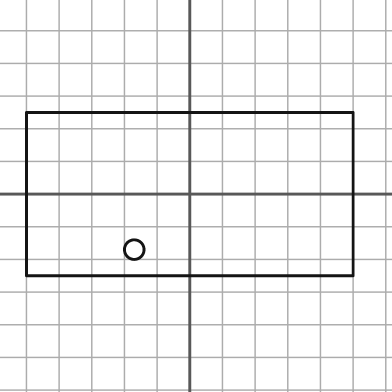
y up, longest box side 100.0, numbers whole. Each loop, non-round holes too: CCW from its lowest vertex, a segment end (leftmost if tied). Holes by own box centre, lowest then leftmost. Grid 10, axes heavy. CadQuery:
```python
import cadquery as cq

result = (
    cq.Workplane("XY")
    .moveTo(-50.0, -25.0)
    .lineTo(50.0, -25.0)
    .lineTo(50.0, 25.0)
    .lineTo(-50.0, 25.0)
    .close()
    .moveTo(-17.0, -17.0)
    .circle(3.0)
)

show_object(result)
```